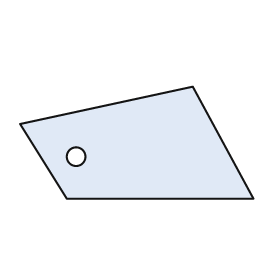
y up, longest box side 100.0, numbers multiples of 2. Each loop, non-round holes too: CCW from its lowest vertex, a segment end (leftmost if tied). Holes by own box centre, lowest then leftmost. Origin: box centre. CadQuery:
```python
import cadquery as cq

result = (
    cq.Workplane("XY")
    .moveTo(-30.0, -24.0)
    .lineTo(50.0, -24.0)
    .lineTo(24.0, 24.0)
    .lineTo(-50.0, 8.0)
    .close()
    .moveTo(-26.0, -6.0)
    .circle(4.0)
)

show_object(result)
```